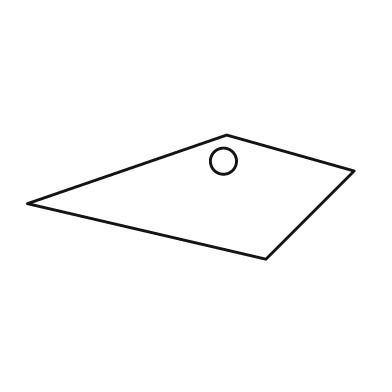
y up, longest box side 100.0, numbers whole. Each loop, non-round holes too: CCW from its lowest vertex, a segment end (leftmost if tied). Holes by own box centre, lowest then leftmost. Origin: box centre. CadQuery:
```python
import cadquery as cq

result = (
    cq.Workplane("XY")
    .moveTo(23.0, -19.0)
    .lineTo(50.0, 8.0)
    .lineTo(11.0, 19.0)
    .lineTo(-50.0, -2.0)
    .close()
    .moveTo(10.0, 11.0)
    .circle(4.0)
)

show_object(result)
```